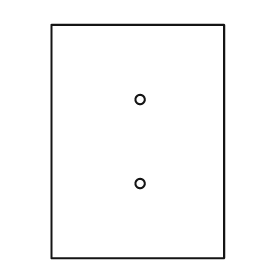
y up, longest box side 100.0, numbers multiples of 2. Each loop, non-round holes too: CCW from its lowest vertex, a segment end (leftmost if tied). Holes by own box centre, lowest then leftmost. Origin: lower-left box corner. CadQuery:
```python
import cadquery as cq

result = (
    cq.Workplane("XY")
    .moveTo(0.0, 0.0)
    .lineTo(74.0, 0.0)
    .lineTo(74.0, 100.0)
    .lineTo(0.0, 100.0)
    .close()
    .moveTo(38.0, 32.0)
    .circle(2.0)
    .moveTo(38.0, 68.0)
    .circle(2.0)
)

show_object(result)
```